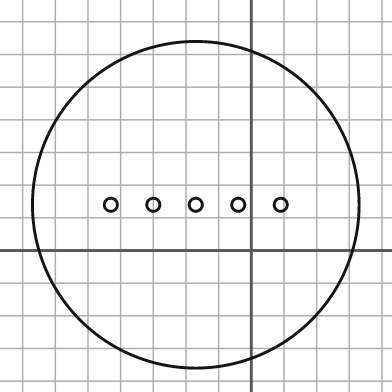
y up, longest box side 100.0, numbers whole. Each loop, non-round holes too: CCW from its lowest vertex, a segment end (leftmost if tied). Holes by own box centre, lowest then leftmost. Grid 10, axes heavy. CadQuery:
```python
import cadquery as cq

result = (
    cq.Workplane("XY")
    .moveTo(-17.0, 14.0)
    .circle(50.0)
    .moveTo(-43.0, 14.0)
    .circle(2.0)
    .moveTo(-30.0, 14.0)
    .circle(2.0)
    .moveTo(-17.0, 14.0)
    .circle(2.0)
    .moveTo(-4.0, 14.0)
    .circle(2.0)
    .moveTo(9.0, 14.0)
    .circle(2.0)
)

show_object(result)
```